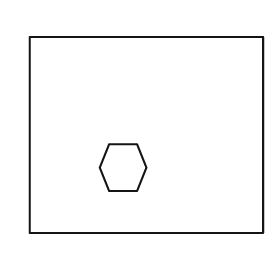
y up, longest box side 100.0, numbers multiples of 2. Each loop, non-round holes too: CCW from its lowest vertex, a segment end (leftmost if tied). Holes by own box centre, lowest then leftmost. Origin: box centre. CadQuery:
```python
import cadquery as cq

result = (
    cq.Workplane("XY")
    .moveTo(-50.0, -42.0)
    .lineTo(50.0, -42.0)
    .lineTo(50.0, 42.0)
    .lineTo(-50.0, 42.0)
    .close()
    .moveTo(-16.0, -24.0)
    .lineTo(-4.0, -24.0)
    .lineTo(0.0, -14.0)
    .lineTo(-4.0, -4.0)
    .lineTo(-16.0, -4.0)
    .lineTo(-20.0, -14.0)
    .close()
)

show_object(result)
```